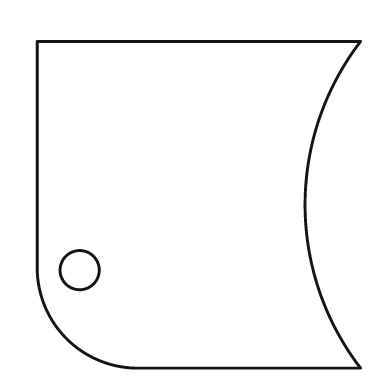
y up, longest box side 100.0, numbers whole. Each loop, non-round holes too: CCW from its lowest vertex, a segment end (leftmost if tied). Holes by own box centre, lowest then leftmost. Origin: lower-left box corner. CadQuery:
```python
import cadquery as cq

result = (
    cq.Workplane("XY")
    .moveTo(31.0, 0.0)
    .lineTo(99.0, 0.0)
    .threePointArc((82.0, 50.0), (99.0, 100.0))
    .lineTo(0.0, 100.0)
    .lineTo(0.0, 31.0)
    .threePointArc((9.0, 9.0), (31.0, 0.0))
    .close()
    .moveTo(13.0, 30.0)
    .circle(6.0)
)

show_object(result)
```